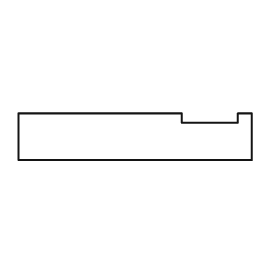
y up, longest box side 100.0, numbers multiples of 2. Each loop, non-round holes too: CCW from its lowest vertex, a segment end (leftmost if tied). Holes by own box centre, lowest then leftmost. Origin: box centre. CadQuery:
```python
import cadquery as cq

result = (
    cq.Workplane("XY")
    .moveTo(-50.0, -10.0)
    .lineTo(50.0, -10.0)
    .lineTo(50.0, 10.0)
    .lineTo(44.0, 10.0)
    .lineTo(44.0, 6.0)
    .lineTo(20.0, 6.0)
    .lineTo(20.0, 10.0)
    .lineTo(-50.0, 10.0)
    .close()
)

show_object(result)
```